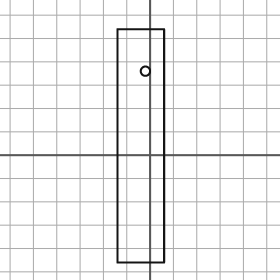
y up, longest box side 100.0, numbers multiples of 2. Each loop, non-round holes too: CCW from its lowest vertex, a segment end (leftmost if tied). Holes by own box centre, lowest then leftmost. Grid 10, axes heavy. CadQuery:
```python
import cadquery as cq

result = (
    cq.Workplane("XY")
    .moveTo(-14.0, -46.0)
    .lineTo(6.0, -46.0)
    .lineTo(6.0, 54.0)
    .lineTo(-14.0, 54.0)
    .close()
    .moveTo(-2.0, 36.0)
    .circle(2.0)
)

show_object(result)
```